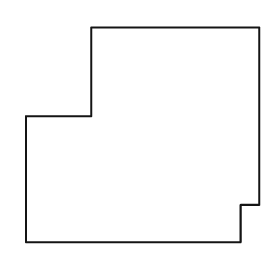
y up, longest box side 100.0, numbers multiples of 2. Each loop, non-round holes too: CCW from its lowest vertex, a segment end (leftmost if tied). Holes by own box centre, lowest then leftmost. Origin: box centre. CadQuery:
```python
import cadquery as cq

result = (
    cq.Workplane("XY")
    .moveTo(-50.0, -46.0)
    .lineTo(42.0, -46.0)
    .lineTo(42.0, -30.0)
    .lineTo(50.0, -30.0)
    .lineTo(50.0, 46.0)
    .lineTo(-22.0, 46.0)
    .lineTo(-22.0, 8.0)
    .lineTo(-50.0, 8.0)
    .close()
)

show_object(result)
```